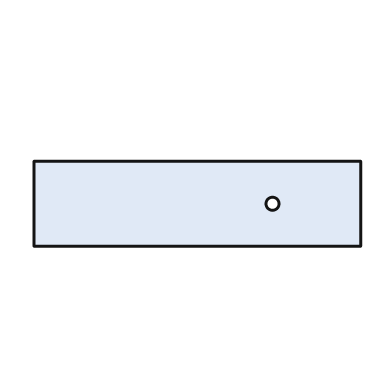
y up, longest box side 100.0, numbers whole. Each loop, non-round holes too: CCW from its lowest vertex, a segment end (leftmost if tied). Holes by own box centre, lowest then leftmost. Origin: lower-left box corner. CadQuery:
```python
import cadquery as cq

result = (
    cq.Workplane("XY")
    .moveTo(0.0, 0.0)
    .lineTo(100.0, 0.0)
    .lineTo(100.0, 26.0)
    .lineTo(0.0, 26.0)
    .close()
    .moveTo(73.0, 13.0)
    .circle(2.0)
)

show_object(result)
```